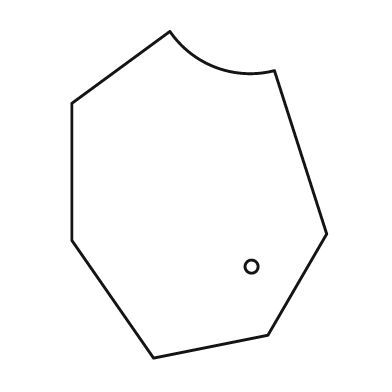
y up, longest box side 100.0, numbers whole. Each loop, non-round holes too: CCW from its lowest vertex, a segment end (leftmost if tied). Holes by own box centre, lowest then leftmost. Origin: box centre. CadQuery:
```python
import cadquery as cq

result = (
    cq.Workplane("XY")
    .moveTo(-14.0, -50.0)
    .lineTo(21.0, -43.0)
    .lineTo(39.0, -12.0)
    .lineTo(23.0, 38.0)
    .threePointArc((5.0, 39.0), (-9.0, 50.0))
    .lineTo(-39.0, 28.0)
    .lineTo(-39.0, -14.0)
    .close()
    .moveTo(16.0, -22.0)
    .circle(2.0)
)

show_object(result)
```